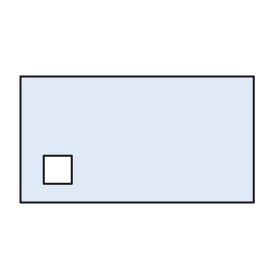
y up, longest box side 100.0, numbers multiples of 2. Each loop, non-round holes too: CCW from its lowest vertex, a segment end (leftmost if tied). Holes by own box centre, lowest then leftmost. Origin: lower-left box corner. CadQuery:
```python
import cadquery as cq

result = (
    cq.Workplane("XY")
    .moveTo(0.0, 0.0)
    .lineTo(100.0, 0.0)
    .lineTo(100.0, 54.0)
    .lineTo(0.0, 54.0)
    .close()
    .moveTo(10.0, 8.0)
    .lineTo(22.0, 8.0)
    .lineTo(22.0, 20.0)
    .lineTo(10.0, 20.0)
    .close()
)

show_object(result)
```